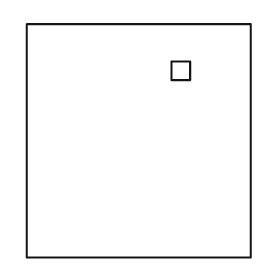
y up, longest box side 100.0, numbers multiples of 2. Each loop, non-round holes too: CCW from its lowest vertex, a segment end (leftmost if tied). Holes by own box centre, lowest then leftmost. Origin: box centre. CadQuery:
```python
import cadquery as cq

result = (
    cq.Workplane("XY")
    .moveTo(-48.0, -50.0)
    .lineTo(48.0, -50.0)
    .lineTo(48.0, 50.0)
    .lineTo(-48.0, 50.0)
    .close()
    .moveTo(14.0, 26.0)
    .lineTo(22.0, 26.0)
    .lineTo(22.0, 34.0)
    .lineTo(14.0, 34.0)
    .close()
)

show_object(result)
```